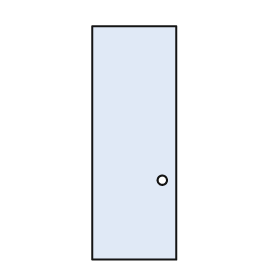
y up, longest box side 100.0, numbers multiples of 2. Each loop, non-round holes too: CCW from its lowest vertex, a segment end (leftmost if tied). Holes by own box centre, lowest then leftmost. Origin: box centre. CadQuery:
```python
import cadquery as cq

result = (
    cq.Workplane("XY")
    .moveTo(-18.0, -50.0)
    .lineTo(18.0, -50.0)
    .lineTo(18.0, 50.0)
    .lineTo(-18.0, 50.0)
    .close()
    .moveTo(12.0, -16.0)
    .circle(2.0)
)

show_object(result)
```